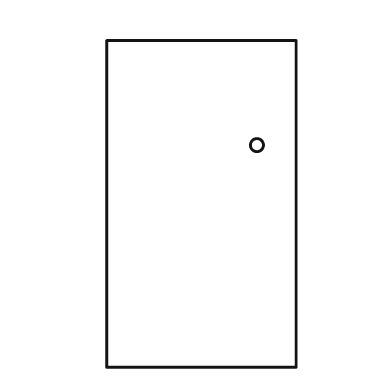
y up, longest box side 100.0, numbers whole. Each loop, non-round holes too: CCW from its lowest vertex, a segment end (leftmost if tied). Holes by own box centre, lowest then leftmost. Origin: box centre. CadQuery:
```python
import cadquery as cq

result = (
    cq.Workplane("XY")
    .moveTo(-29.0, -50.0)
    .lineTo(29.0, -50.0)
    .lineTo(29.0, 50.0)
    .lineTo(-29.0, 50.0)
    .close()
    .moveTo(17.0, 18.0)
    .circle(2.0)
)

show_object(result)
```